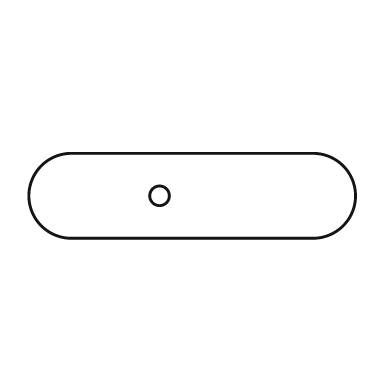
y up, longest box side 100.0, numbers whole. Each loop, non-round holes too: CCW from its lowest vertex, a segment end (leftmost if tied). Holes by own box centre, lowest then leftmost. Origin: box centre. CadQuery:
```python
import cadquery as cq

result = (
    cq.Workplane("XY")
    .moveTo(-37.0, -13.0)
    .lineTo(37.0, -13.0)
    .threePointArc((50.0, 0.0), (37.0, 13.0))
    .lineTo(-37.0, 13.0)
    .threePointArc((-50.0, 0.0), (-37.0, -13.0))
    .close()
    .moveTo(-10.0, 0.0)
    .circle(3.0)
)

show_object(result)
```